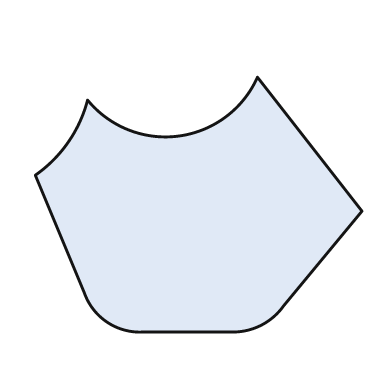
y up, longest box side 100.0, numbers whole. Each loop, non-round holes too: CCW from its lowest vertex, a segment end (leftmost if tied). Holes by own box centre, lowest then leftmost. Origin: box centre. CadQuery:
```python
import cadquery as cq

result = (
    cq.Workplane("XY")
    .moveTo(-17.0, -39.0)
    .lineTo(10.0, -39.0)
    .threePointArc((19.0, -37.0), (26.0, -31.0))
    .lineTo(50.0, -2.0)
    .lineTo(18.0, 39.0)
    .threePointArc((-6.0, 21.0), (-34.0, 32.0))
    .threePointArc((-40.0, 19.0), (-50.0, 9.0))
    .lineTo(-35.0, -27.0)
    .threePointArc((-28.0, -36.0), (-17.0, -39.0))
    .close()
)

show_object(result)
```